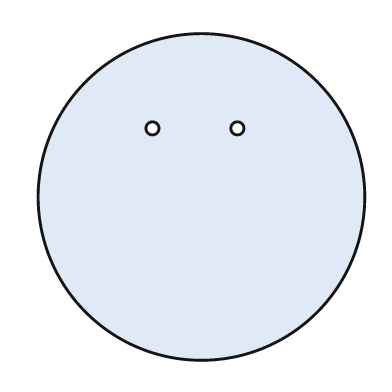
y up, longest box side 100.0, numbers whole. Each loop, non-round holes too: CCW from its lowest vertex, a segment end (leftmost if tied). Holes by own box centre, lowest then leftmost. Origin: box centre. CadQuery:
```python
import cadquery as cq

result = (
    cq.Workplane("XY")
    .moveTo(0.0, 0.0)
    .circle(50.0)
    .moveTo(-15.0, 21.0)
    .circle(2.0)
    .moveTo(11.0, 21.0)
    .circle(2.0)
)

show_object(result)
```